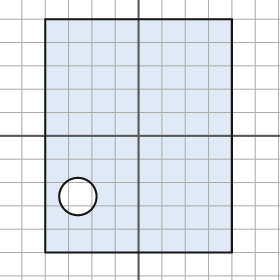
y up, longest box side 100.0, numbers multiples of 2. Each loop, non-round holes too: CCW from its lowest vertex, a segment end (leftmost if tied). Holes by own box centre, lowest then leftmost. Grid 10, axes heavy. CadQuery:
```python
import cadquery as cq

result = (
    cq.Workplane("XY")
    .moveTo(-40.0, -50.0)
    .lineTo(40.0, -50.0)
    .lineTo(40.0, 50.0)
    .lineTo(-40.0, 50.0)
    .close()
    .moveTo(-26.0, -26.0)
    .circle(8.0)
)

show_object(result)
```